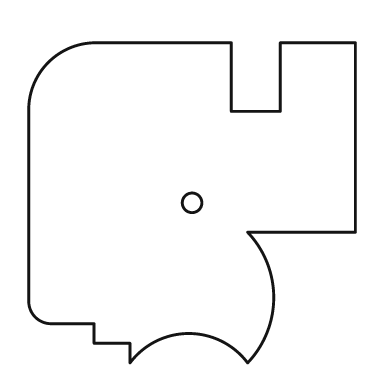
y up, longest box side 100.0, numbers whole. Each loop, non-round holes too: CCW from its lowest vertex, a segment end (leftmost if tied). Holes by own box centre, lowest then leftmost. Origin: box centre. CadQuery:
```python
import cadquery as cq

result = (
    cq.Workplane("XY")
    .moveTo(-19.0, -49.0)
    .threePointArc((-1.0, -40.0), (17.0, -49.0))
    .threePointArc((25.0, -29.0), (17.0, -9.0))
    .lineTo(50.0, -9.0)
    .lineTo(50.0, 49.0)
    .lineTo(27.0, 49.0)
    .lineTo(27.0, 28.0)
    .lineTo(12.0, 28.0)
    .lineTo(12.0, 49.0)
    .lineTo(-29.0, 49.0)
    .threePointArc((-44.0, 43.0), (-50.0, 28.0))
    .lineTo(-50.0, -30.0)
    .threePointArc((-48.0, -35.0), (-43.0, -37.0))
    .lineTo(-30.0, -37.0)
    .lineTo(-30.0, -43.0)
    .lineTo(-19.0, -43.0)
    .close()
    .moveTo(0.0, 0.0)
    .circle(3.0)
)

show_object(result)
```